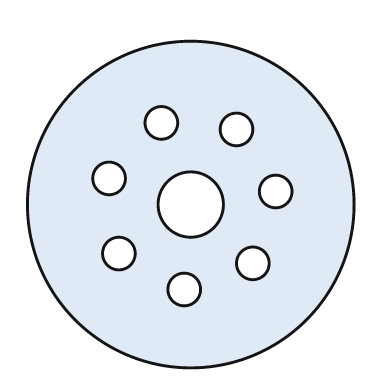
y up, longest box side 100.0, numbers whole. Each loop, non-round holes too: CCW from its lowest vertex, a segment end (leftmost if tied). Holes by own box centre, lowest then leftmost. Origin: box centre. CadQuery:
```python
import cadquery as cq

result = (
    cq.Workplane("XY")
    .moveTo(0.0, 0.0)
    .circle(50.0)
    .moveTo(-2.0, -26.0)
    .circle(5.0)
    .moveTo(19.0, -18.0)
    .circle(5.0)
    .moveTo(-22.0, -15.0)
    .circle(5.0)
    .moveTo(0.0, 0.0)
    .circle(10.0)
    .moveTo(26.0, 4.0)
    .circle(5.0)
    .moveTo(-25.0, 8.0)
    .circle(5.0)
    .moveTo(14.0, 23.0)
    .circle(5.0)
    .moveTo(-9.0, 25.0)
    .circle(5.0)
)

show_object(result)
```